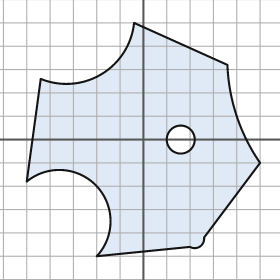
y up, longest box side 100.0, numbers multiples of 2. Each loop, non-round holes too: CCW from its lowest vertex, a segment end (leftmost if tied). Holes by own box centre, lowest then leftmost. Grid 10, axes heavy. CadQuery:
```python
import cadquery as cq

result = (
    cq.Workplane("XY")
    .moveTo(-20.0, -50.0)
    .lineTo(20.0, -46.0)
    .threePointArc((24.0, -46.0), (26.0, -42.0))
    .lineTo(50.0, -10.0)
    .threePointArc((40.0, 10.0), (36.0, 32.0))
    .lineTo(-4.0, 50.0)
    .threePointArc((-18.0, 28.0), (-44.0, 26.0))
    .lineTo(-50.0, -18.0)
    .threePointArc((-20.0, -20.0), (-20.0, -50.0))
    .close()
    .moveTo(16.0, 0.0)
    .circle(6.0)
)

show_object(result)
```